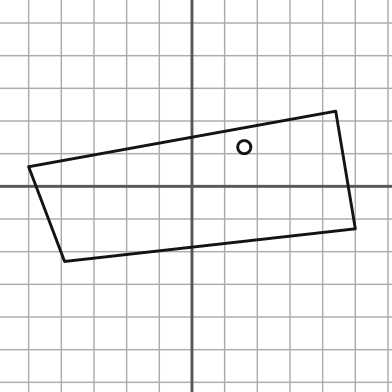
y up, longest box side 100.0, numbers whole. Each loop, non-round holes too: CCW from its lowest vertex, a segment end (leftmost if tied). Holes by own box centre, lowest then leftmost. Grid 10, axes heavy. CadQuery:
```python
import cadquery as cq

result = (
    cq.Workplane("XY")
    .moveTo(-39.0, -23.0)
    .lineTo(50.0, -13.0)
    .lineTo(44.0, 23.0)
    .lineTo(-50.0, 6.0)
    .close()
    .moveTo(16.0, 12.0)
    .circle(2.0)
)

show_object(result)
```